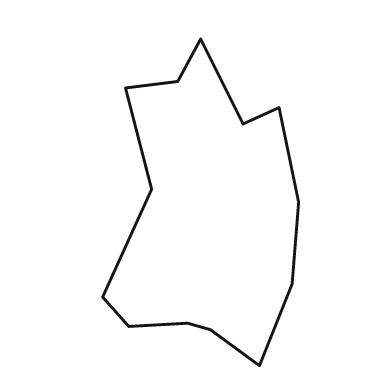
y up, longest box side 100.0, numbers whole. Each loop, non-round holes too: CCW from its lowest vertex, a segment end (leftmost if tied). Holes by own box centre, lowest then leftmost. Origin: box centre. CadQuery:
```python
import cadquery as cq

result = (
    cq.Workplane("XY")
    .moveTo(18.0, -50.0)
    .lineTo(28.0, -25.0)
    .lineTo(30.0, 0.0)
    .lineTo(24.0, 29.0)
    .lineTo(13.0, 24.0)
    .lineTo(0.0, 50.0)
    .lineTo(-7.0, 37.0)
    .lineTo(-23.0, 35.0)
    .lineTo(-15.0, 4.0)
    .lineTo(-30.0, -29.0)
    .lineTo(-22.0, -38.0)
    .lineTo(-4.0, -37.0)
    .lineTo(3.0, -39.0)
    .close()
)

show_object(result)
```